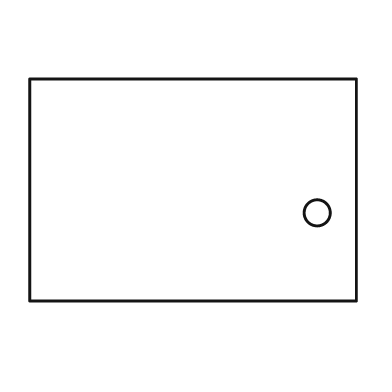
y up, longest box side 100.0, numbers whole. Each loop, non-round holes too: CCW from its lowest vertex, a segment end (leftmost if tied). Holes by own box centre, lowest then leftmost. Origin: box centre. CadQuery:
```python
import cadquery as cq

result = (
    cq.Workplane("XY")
    .moveTo(-50.0, -34.0)
    .lineTo(50.0, -34.0)
    .lineTo(50.0, 34.0)
    .lineTo(-50.0, 34.0)
    .close()
    .moveTo(38.0, -7.0)
    .circle(4.0)
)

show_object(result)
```